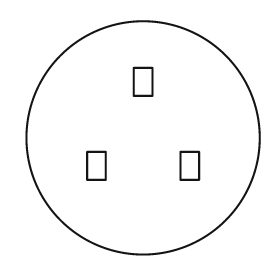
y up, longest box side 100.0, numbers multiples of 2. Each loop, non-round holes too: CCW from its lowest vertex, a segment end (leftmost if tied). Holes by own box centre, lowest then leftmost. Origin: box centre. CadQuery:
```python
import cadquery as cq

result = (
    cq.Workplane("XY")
    .moveTo(0.0, 0.0)
    .circle(50.0)
    .moveTo(-24.0, -18.0)
    .lineTo(-16.0, -18.0)
    .lineTo(-16.0, -6.0)
    .lineTo(-24.0, -6.0)
    .close()
    .moveTo(16.0, -18.0)
    .lineTo(24.0, -18.0)
    .lineTo(24.0, -6.0)
    .lineTo(16.0, -6.0)
    .close()
    .moveTo(-4.0, 18.0)
    .lineTo(4.0, 18.0)
    .lineTo(4.0, 30.0)
    .lineTo(-4.0, 30.0)
    .close()
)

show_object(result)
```